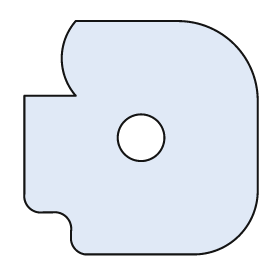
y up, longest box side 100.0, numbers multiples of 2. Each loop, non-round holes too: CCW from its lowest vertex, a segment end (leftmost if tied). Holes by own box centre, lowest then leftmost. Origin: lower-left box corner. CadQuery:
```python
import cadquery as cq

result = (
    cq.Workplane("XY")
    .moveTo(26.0, 0.0)
    .lineTo(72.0, 0.0)
    .threePointArc((92.0, 8.0), (100.0, 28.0))
    .lineTo(100.0, 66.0)
    .threePointArc((90.0, 90.0), (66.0, 100.0))
    .lineTo(22.0, 100.0)
    .threePointArc((16.0, 84.0), (22.0, 68.0))
    .lineTo(0.0, 68.0)
    .lineTo(0.0, 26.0)
    .threePointArc((2.0, 20.0), (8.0, 18.0))
    .lineTo(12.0, 18.0)
    .threePointArc((18.0, 16.0), (20.0, 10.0))
    .lineTo(20.0, 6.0)
    .threePointArc((22.0, 2.0), (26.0, 0.0))
    .close()
    .moveTo(50.0, 50.0)
    .circle(10.0)
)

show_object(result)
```